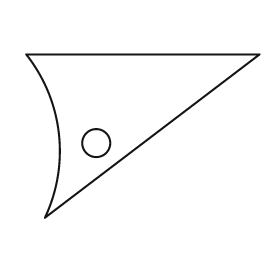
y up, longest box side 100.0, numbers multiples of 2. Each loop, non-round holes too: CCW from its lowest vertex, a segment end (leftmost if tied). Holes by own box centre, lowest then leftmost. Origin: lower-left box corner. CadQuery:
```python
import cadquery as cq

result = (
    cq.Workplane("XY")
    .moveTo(8.0, 0.0)
    .lineTo(100.0, 70.0)
    .lineTo(0.0, 70.0)
    .threePointArc((14.0, 36.0), (8.0, 0.0))
    .close()
    .moveTo(30.0, 32.0)
    .circle(6.0)
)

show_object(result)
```